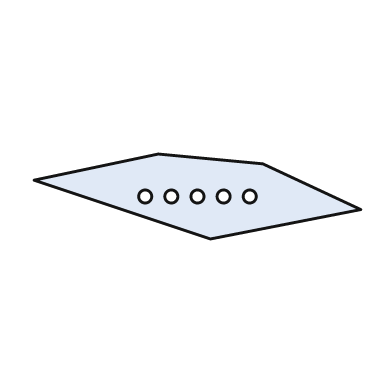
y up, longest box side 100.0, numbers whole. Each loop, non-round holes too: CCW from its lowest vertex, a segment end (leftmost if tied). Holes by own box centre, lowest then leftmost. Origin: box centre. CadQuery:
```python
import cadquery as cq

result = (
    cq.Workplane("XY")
    .moveTo(4.0, -13.0)
    .lineTo(50.0, -4.0)
    .lineTo(20.0, 10.0)
    .lineTo(-12.0, 13.0)
    .lineTo(-50.0, 5.0)
    .close()
    .moveTo(-16.0, 0.0)
    .circle(2.0)
    .moveTo(-8.0, 0.0)
    .circle(2.0)
    .moveTo(0.0, 0.0)
    .circle(2.0)
    .moveTo(8.0, 0.0)
    .circle(2.0)
    .moveTo(16.0, 0.0)
    .circle(2.0)
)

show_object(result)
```